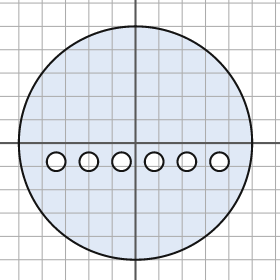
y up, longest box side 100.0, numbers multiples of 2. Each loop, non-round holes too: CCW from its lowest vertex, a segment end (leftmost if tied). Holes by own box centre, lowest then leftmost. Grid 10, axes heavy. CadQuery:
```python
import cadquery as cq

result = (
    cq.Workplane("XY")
    .moveTo(0.0, 0.0)
    .circle(50.0)
    .moveTo(-34.0, -8.0)
    .circle(4.0)
    .moveTo(-20.0, -8.0)
    .circle(4.0)
    .moveTo(-6.0, -8.0)
    .circle(4.0)
    .moveTo(8.0, -8.0)
    .circle(4.0)
    .moveTo(22.0, -8.0)
    .circle(4.0)
    .moveTo(36.0, -8.0)
    .circle(4.0)
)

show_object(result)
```